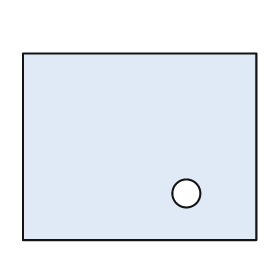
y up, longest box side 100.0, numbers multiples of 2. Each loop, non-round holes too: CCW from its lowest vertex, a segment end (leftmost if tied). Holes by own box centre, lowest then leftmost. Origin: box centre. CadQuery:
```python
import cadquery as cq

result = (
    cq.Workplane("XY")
    .moveTo(-50.0, -40.0)
    .lineTo(50.0, -40.0)
    .lineTo(50.0, 40.0)
    .lineTo(-50.0, 40.0)
    .close()
    .moveTo(20.0, -20.0)
    .circle(6.0)
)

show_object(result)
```